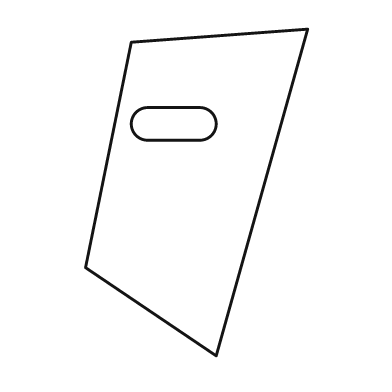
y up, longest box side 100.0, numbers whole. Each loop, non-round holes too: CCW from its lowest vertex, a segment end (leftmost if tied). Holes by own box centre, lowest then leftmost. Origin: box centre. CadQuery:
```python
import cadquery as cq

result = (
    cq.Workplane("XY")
    .moveTo(6.0, -50.0)
    .lineTo(34.0, 50.0)
    .lineTo(-20.0, 46.0)
    .lineTo(-34.0, -23.0)
    .close()
    .moveTo(-15.0, 16.0)
    .lineTo(1.0, 16.0)
    .threePointArc((6.0, 21.0), (1.0, 26.0))
    .lineTo(-15.0, 26.0)
    .threePointArc((-20.0, 21.0), (-15.0, 16.0))
    .close()
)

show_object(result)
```